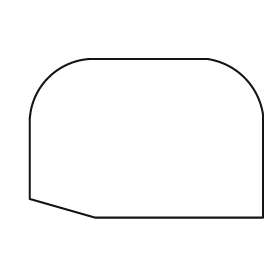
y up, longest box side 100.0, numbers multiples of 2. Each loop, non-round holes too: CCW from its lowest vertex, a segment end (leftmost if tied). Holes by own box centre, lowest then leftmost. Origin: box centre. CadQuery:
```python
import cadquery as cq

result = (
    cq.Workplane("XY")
    .moveTo(-22.0, -34.0)
    .lineTo(50.0, -34.0)
    .lineTo(50.0, 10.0)
    .threePointArc((42.0, 26.0), (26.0, 34.0))
    .lineTo(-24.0, 34.0)
    .threePointArc((-42.0, 26.0), (-50.0, 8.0))
    .lineTo(-50.0, -26.0)
    .close()
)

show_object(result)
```